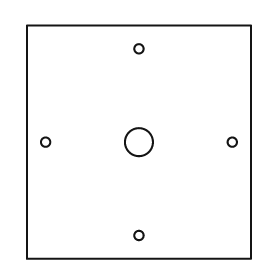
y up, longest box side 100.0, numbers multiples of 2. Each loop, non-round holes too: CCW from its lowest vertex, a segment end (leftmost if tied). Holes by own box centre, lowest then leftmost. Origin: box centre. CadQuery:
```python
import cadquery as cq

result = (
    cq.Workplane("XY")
    .moveTo(-48.0, -50.0)
    .lineTo(48.0, -50.0)
    .lineTo(48.0, 50.0)
    .lineTo(-48.0, 50.0)
    .close()
    .moveTo(0.0, -40.0)
    .circle(2.0)
    .moveTo(-40.0, 0.0)
    .circle(2.0)
    .moveTo(0.0, 0.0)
    .circle(6.0)
    .moveTo(40.0, 0.0)
    .circle(2.0)
    .moveTo(0.0, 40.0)
    .circle(2.0)
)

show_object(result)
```